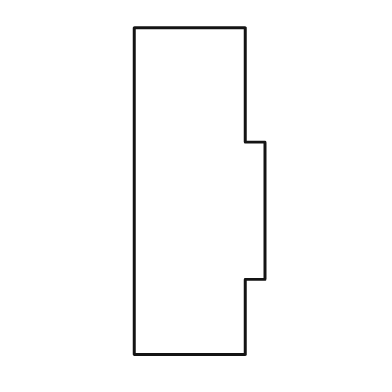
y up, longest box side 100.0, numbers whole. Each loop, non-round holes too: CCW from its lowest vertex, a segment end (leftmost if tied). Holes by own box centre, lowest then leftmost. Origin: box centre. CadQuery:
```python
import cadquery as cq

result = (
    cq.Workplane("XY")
    .moveTo(-20.0, -50.0)
    .lineTo(14.0, -50.0)
    .lineTo(14.0, -27.0)
    .lineTo(20.0, -27.0)
    .lineTo(20.0, 15.0)
    .lineTo(14.0, 15.0)
    .lineTo(14.0, 50.0)
    .lineTo(-20.0, 50.0)
    .close()
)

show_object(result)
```